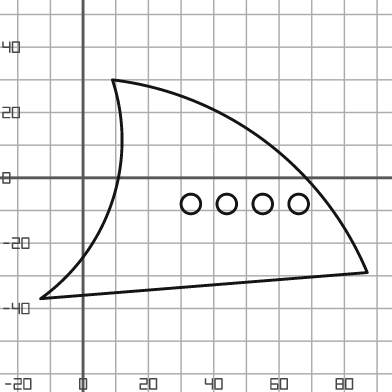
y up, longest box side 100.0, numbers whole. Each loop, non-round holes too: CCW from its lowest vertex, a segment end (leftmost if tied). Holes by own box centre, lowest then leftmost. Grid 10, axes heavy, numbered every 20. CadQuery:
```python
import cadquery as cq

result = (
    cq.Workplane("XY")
    .moveTo(-13.0, -37.0)
    .lineTo(87.0, -29.0)
    .threePointArc((56.0, 11.0), (9.0, 30.0))
    .threePointArc((9.0, -7.0), (-13.0, -37.0))
    .close()
    .moveTo(33.0, -8.0)
    .circle(3.0)
    .moveTo(44.0, -8.0)
    .circle(3.0)
    .moveTo(55.0, -8.0)
    .circle(3.0)
    .moveTo(66.0, -8.0)
    .circle(3.0)
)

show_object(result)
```